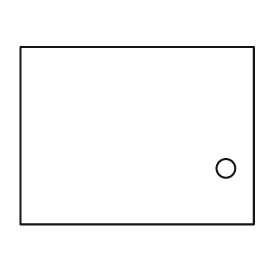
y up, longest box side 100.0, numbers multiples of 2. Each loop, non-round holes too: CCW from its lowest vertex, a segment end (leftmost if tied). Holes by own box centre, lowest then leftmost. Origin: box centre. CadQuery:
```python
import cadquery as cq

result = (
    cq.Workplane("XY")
    .moveTo(-50.0, -38.0)
    .lineTo(50.0, -38.0)
    .lineTo(50.0, 38.0)
    .lineTo(-50.0, 38.0)
    .close()
    .moveTo(38.0, -14.0)
    .circle(4.0)
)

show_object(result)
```